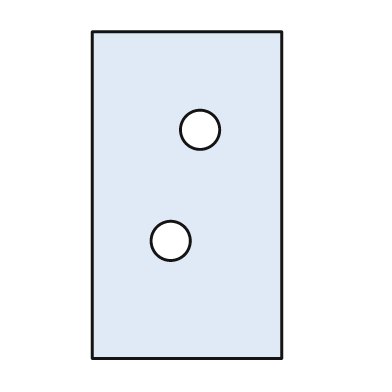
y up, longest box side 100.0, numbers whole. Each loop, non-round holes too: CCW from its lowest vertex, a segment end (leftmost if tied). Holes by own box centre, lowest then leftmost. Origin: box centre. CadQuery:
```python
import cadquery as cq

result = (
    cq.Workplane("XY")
    .moveTo(-29.0, -50.0)
    .lineTo(29.0, -50.0)
    .lineTo(29.0, 50.0)
    .lineTo(-29.0, 50.0)
    .close()
    .moveTo(-5.0, -14.0)
    .circle(6.0)
    .moveTo(4.0, 20.0)
    .circle(6.0)
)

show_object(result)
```